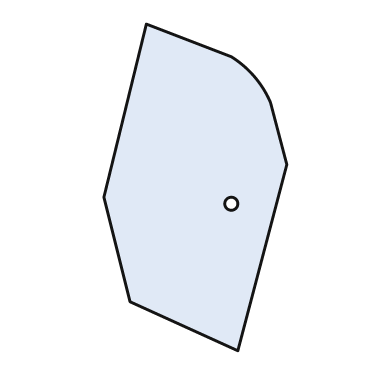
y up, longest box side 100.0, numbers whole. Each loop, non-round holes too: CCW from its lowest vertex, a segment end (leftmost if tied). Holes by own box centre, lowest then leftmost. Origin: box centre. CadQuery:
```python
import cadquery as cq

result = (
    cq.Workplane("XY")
    .moveTo(13.0, -50.0)
    .lineTo(28.0, 7.0)
    .lineTo(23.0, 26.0)
    .threePointArc((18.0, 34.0), (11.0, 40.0))
    .lineTo(-15.0, 50.0)
    .lineTo(-28.0, -3.0)
    .lineTo(-20.0, -35.0)
    .close()
    .moveTo(11.0, -5.0)
    .circle(2.0)
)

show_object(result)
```